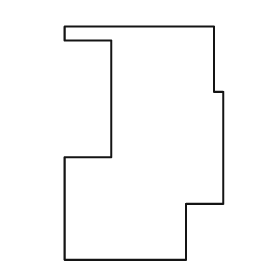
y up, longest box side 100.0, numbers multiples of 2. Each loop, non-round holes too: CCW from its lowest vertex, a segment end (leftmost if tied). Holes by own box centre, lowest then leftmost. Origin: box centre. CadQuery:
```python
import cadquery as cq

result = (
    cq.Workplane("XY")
    .moveTo(-34.0, -50.0)
    .lineTo(18.0, -50.0)
    .lineTo(18.0, -26.0)
    .lineTo(34.0, -26.0)
    .lineTo(34.0, 22.0)
    .lineTo(30.0, 22.0)
    .lineTo(30.0, 50.0)
    .lineTo(-34.0, 50.0)
    .lineTo(-34.0, 44.0)
    .lineTo(-14.0, 44.0)
    .lineTo(-14.0, -6.0)
    .lineTo(-34.0, -6.0)
    .close()
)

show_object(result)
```